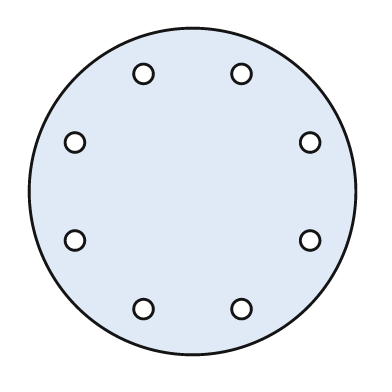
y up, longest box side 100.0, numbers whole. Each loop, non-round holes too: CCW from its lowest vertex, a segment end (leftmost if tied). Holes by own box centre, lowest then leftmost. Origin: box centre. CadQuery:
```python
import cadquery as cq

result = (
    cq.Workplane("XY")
    .moveTo(0.0, 0.0)
    .circle(50.0)
    .moveTo(-15.0, -36.0)
    .circle(3.0)
    .moveTo(15.0, -36.0)
    .circle(3.0)
    .moveTo(-36.0, -15.0)
    .circle(3.0)
    .moveTo(36.0, -15.0)
    .circle(3.0)
    .moveTo(-36.0, 15.0)
    .circle(3.0)
    .moveTo(36.0, 15.0)
    .circle(3.0)
    .moveTo(-15.0, 36.0)
    .circle(3.0)
    .moveTo(15.0, 36.0)
    .circle(3.0)
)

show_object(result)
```